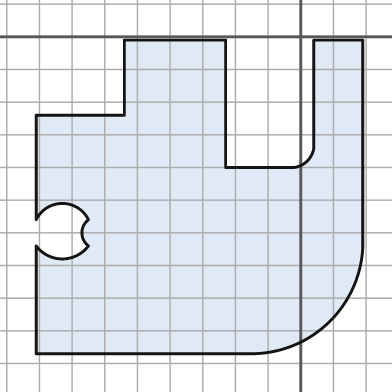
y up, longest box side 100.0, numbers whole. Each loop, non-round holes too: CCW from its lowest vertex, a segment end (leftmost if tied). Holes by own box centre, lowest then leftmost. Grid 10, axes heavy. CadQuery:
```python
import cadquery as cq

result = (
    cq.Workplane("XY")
    .moveTo(-81.0, -97.0)
    .lineTo(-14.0, -97.0)
    .threePointArc((9.0, -87.0), (19.0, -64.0))
    .lineTo(19.0, -1.0)
    .lineTo(4.0, -1.0)
    .lineTo(4.0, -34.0)
    .threePointArc((2.0, -38.0), (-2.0, -40.0))
    .lineTo(-23.0, -40.0)
    .lineTo(-23.0, -1.0)
    .lineTo(-54.0, -1.0)
    .lineTo(-54.0, -24.0)
    .lineTo(-81.0, -24.0)
    .lineTo(-81.0, -56.0)
    .threePointArc((-73.0, -51.0), (-65.0, -56.0))
    .threePointArc((-67.0, -60.0), (-65.0, -64.0))
    .threePointArc((-73.0, -68.0), (-81.0, -64.0))
    .close()
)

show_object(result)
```